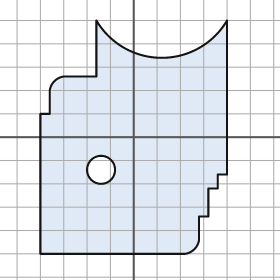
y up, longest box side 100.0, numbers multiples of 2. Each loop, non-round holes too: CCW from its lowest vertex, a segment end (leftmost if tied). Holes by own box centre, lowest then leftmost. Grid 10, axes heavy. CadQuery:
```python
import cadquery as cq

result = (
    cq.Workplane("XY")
    .moveTo(-40.0, -50.0)
    .lineTo(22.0, -50.0)
    .threePointArc((26.0, -48.0), (28.0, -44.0))
    .lineTo(28.0, -34.0)
    .lineTo(32.0, -34.0)
    .lineTo(32.0, -22.0)
    .lineTo(36.0, -22.0)
    .lineTo(36.0, -16.0)
    .lineTo(40.0, -16.0)
    .lineTo(40.0, 50.0)
    .threePointArc((12.0, 34.0), (-16.0, 50.0))
    .lineTo(-16.0, 26.0)
    .lineTo(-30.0, 26.0)
    .threePointArc((-34.0, 24.0), (-36.0, 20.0))
    .lineTo(-36.0, 10.0)
    .lineTo(-40.0, 10.0)
    .close()
    .moveTo(-14.0, -14.0)
    .circle(6.0)
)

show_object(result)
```